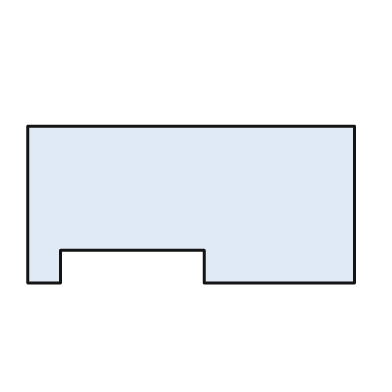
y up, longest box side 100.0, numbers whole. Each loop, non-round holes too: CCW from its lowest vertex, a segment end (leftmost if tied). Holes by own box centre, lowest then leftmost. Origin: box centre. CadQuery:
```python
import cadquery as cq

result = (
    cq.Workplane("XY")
    .moveTo(-50.0, -24.0)
    .lineTo(-40.0, -24.0)
    .lineTo(-40.0, -14.0)
    .lineTo(4.0, -14.0)
    .lineTo(4.0, -24.0)
    .lineTo(50.0, -24.0)
    .lineTo(50.0, 24.0)
    .lineTo(-50.0, 24.0)
    .close()
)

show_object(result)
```